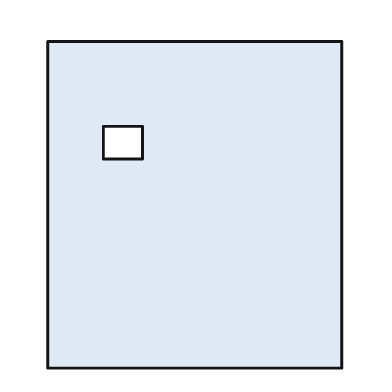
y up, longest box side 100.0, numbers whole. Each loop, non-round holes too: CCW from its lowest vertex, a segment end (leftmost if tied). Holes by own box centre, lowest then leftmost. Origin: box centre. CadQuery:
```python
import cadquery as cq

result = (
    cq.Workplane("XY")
    .moveTo(-45.0, -50.0)
    .lineTo(45.0, -50.0)
    .lineTo(45.0, 50.0)
    .lineTo(-45.0, 50.0)
    .close()
    .moveTo(-28.0, 14.0)
    .lineTo(-16.0, 14.0)
    .lineTo(-16.0, 24.0)
    .lineTo(-28.0, 24.0)
    .close()
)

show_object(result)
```